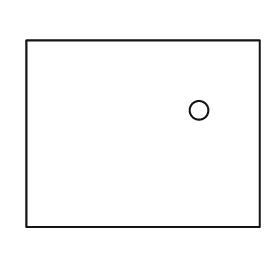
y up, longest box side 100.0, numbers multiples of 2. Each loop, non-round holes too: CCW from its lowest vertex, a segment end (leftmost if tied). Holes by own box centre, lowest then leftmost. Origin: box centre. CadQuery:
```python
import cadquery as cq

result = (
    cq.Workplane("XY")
    .moveTo(-50.0, -40.0)
    .lineTo(50.0, -40.0)
    .lineTo(50.0, 40.0)
    .lineTo(-50.0, 40.0)
    .close()
    .moveTo(24.0, 10.0)
    .circle(4.0)
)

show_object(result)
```